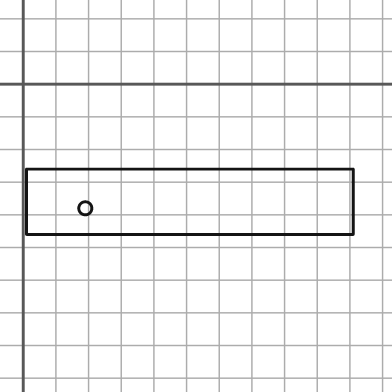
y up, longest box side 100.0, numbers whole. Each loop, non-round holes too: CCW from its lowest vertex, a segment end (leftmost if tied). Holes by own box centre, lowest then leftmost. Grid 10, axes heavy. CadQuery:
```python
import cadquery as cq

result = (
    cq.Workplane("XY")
    .moveTo(1.0, -46.0)
    .lineTo(101.0, -46.0)
    .lineTo(101.0, -26.0)
    .lineTo(1.0, -26.0)
    .close()
    .moveTo(19.0, -38.0)
    .circle(2.0)
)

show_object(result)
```